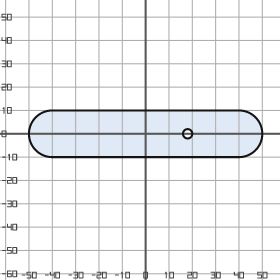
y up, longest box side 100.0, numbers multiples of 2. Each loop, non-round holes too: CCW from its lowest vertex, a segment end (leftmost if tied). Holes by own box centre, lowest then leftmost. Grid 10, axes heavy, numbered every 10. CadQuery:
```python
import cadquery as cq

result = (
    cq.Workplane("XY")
    .moveTo(-40.0, -10.0)
    .lineTo(40.0, -10.0)
    .threePointArc((50.0, 0.0), (40.0, 10.0))
    .lineTo(-40.0, 10.0)
    .threePointArc((-50.0, 0.0), (-40.0, -10.0))
    .close()
    .moveTo(18.0, 0.0)
    .circle(2.0)
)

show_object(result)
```